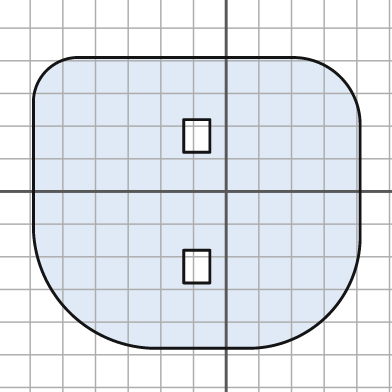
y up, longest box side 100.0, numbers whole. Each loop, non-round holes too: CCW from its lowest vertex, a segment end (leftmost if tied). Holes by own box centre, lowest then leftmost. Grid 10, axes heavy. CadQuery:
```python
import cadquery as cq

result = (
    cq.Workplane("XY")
    .moveTo(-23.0, -48.0)
    .lineTo(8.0, -48.0)
    .threePointArc((31.0, -38.0), (41.0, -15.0))
    .lineTo(41.0, 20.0)
    .threePointArc((35.0, 35.0), (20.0, 41.0))
    .lineTo(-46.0, 41.0)
    .threePointArc((-55.0, 37.0), (-59.0, 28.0))
    .lineTo(-59.0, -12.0)
    .threePointArc((-48.0, -37.0), (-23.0, -48.0))
    .close()
    .moveTo(-13.0, -28.0)
    .lineTo(-5.0, -28.0)
    .lineTo(-5.0, -18.0)
    .lineTo(-13.0, -18.0)
    .close()
    .moveTo(-13.0, 12.0)
    .lineTo(-5.0, 12.0)
    .lineTo(-5.0, 22.0)
    .lineTo(-13.0, 22.0)
    .close()
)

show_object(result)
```